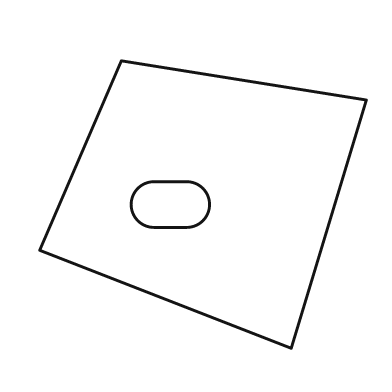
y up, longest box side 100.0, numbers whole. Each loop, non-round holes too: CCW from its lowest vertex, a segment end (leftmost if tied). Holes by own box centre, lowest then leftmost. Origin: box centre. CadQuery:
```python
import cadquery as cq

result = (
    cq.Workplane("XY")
    .moveTo(27.0, -44.0)
    .lineTo(50.0, 32.0)
    .lineTo(-25.0, 44.0)
    .lineTo(-50.0, -14.0)
    .close()
    .moveTo(-15.0, -7.0)
    .lineTo(-5.0, -7.0)
    .threePointArc((2.0, 0.0), (-5.0, 7.0))
    .lineTo(-15.0, 7.0)
    .threePointArc((-22.0, 0.0), (-15.0, -7.0))
    .close()
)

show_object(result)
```